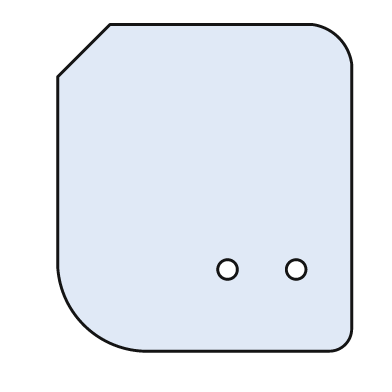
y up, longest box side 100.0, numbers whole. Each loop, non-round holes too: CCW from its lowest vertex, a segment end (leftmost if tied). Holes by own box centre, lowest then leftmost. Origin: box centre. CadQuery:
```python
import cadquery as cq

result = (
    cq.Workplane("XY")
    .moveTo(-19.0, -50.0)
    .lineTo(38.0, -50.0)
    .threePointArc((43.0, -48.0), (45.0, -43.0))
    .lineTo(45.0, 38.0)
    .threePointArc((41.0, 46.0), (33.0, 50.0))
    .lineTo(-29.0, 50.0)
    .lineTo(-45.0, 34.0)
    .lineTo(-45.0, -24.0)
    .threePointArc((-37.0, -42.0), (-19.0, -50.0))
    .close()
    .moveTo(7.0, -25.0)
    .circle(3.0)
    .moveTo(28.0, -25.0)
    .circle(3.0)
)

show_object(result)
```